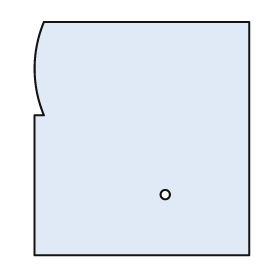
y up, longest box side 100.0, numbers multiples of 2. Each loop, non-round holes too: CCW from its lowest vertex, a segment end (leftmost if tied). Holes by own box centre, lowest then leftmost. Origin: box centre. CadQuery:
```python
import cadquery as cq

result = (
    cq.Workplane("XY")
    .moveTo(-46.0, -50.0)
    .lineTo(46.0, -50.0)
    .lineTo(46.0, 50.0)
    .lineTo(-42.0, 50.0)
    .threePointArc((-46.0, 30.0), (-42.0, 10.0))
    .lineTo(-46.0, 10.0)
    .close()
    .moveTo(10.0, -24.0)
    .circle(2.0)
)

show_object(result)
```